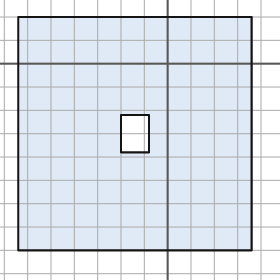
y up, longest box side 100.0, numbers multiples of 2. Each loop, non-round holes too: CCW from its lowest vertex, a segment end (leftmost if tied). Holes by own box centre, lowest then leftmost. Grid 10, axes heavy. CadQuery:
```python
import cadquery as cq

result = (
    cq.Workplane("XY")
    .moveTo(-64.0, -80.0)
    .lineTo(36.0, -80.0)
    .lineTo(36.0, 20.0)
    .lineTo(-64.0, 20.0)
    .close()
    .moveTo(-20.0, -38.0)
    .lineTo(-8.0, -38.0)
    .lineTo(-8.0, -22.0)
    .lineTo(-20.0, -22.0)
    .close()
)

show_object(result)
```